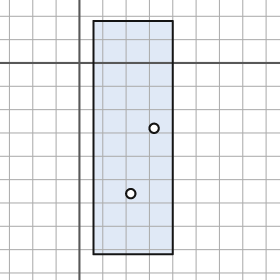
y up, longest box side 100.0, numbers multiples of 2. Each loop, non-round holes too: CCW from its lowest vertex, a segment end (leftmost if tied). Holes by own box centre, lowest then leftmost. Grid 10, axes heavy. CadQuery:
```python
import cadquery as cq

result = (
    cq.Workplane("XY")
    .moveTo(6.0, -82.0)
    .lineTo(40.0, -82.0)
    .lineTo(40.0, 18.0)
    .lineTo(6.0, 18.0)
    .close()
    .moveTo(22.0, -56.0)
    .circle(2.0)
    .moveTo(32.0, -28.0)
    .circle(2.0)
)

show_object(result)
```